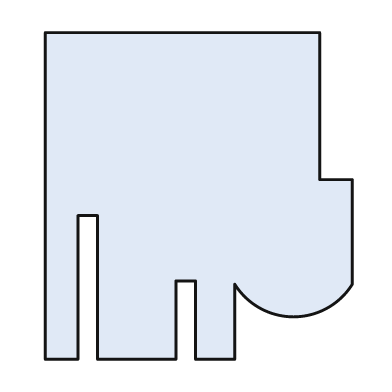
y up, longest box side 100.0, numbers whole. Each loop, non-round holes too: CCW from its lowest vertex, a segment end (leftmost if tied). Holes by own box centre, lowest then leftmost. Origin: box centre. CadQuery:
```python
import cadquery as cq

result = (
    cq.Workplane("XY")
    .moveTo(-47.0, -50.0)
    .lineTo(-37.0, -50.0)
    .lineTo(-37.0, -6.0)
    .lineTo(-31.0, -6.0)
    .lineTo(-31.0, -50.0)
    .lineTo(-7.0, -50.0)
    .lineTo(-7.0, -26.0)
    .lineTo(-1.0, -26.0)
    .lineTo(-1.0, -50.0)
    .lineTo(11.0, -50.0)
    .lineTo(11.0, -27.0)
    .threePointArc((29.0, -37.0), (47.0, -27.0))
    .lineTo(47.0, 5.0)
    .lineTo(37.0, 5.0)
    .lineTo(37.0, 50.0)
    .lineTo(-47.0, 50.0)
    .close()
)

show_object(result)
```